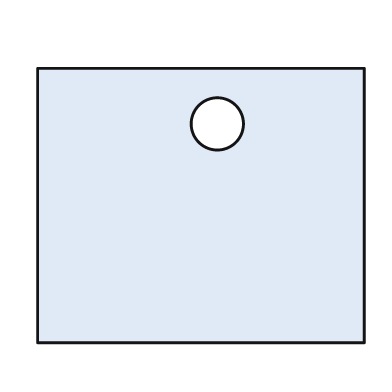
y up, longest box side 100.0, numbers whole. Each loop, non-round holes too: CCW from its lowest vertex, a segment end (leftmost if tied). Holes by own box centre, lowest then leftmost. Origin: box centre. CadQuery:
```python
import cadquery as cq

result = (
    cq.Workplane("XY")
    .moveTo(-50.0, -42.0)
    .lineTo(50.0, -42.0)
    .lineTo(50.0, 42.0)
    .lineTo(-50.0, 42.0)
    .close()
    .moveTo(5.0, 25.0)
    .circle(8.0)
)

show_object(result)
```